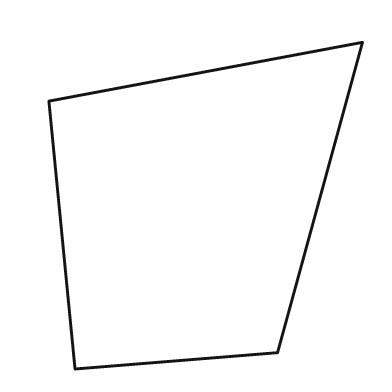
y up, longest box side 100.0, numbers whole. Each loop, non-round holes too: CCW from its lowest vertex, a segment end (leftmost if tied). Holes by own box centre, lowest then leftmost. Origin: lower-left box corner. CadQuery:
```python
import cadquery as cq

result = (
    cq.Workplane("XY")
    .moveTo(8.0, 0.0)
    .lineTo(70.0, 5.0)
    .lineTo(96.0, 100.0)
    .lineTo(0.0, 82.0)
    .close()
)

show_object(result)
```